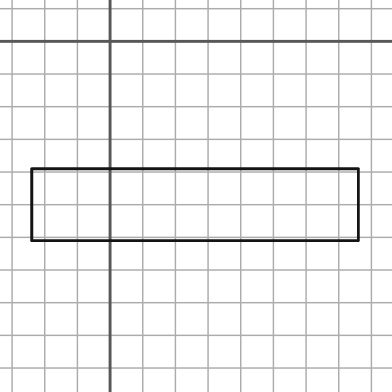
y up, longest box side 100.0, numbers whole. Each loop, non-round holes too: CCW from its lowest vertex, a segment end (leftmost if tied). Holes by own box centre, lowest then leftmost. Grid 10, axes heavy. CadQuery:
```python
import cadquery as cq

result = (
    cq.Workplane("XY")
    .moveTo(-24.0, -61.0)
    .lineTo(76.0, -61.0)
    .lineTo(76.0, -39.0)
    .lineTo(-24.0, -39.0)
    .close()
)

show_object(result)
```